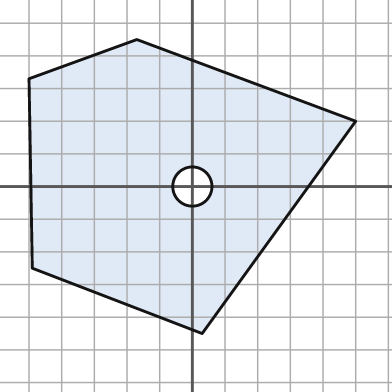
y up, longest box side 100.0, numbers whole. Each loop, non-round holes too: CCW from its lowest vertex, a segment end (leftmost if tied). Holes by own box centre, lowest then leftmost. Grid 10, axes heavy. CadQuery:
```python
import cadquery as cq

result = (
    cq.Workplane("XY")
    .moveTo(3.0, -45.0)
    .lineTo(50.0, 20.0)
    .lineTo(-17.0, 45.0)
    .lineTo(-50.0, 33.0)
    .lineTo(-49.0, -25.0)
    .close()
    .moveTo(0.0, 0.0)
    .circle(6.0)
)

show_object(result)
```